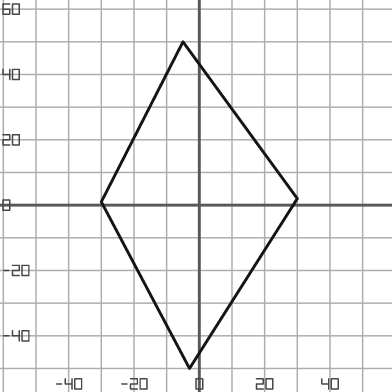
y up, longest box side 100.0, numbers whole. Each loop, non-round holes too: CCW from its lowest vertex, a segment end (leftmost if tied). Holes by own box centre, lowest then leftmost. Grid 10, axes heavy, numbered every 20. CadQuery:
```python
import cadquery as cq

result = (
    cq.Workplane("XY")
    .moveTo(-3.0, -50.0)
    .lineTo(30.0, 2.0)
    .lineTo(-5.0, 50.0)
    .lineTo(-30.0, 1.0)
    .close()
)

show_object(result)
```